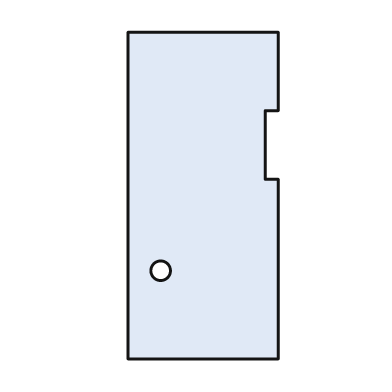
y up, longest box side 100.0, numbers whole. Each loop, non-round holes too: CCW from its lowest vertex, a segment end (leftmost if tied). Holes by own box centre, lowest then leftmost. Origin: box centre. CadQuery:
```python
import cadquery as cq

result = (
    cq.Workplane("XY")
    .moveTo(-23.0, -50.0)
    .lineTo(23.0, -50.0)
    .lineTo(23.0, 5.0)
    .lineTo(19.0, 5.0)
    .lineTo(19.0, 26.0)
    .lineTo(23.0, 26.0)
    .lineTo(23.0, 50.0)
    .lineTo(-23.0, 50.0)
    .close()
    .moveTo(-13.0, -23.0)
    .circle(3.0)
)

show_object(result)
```